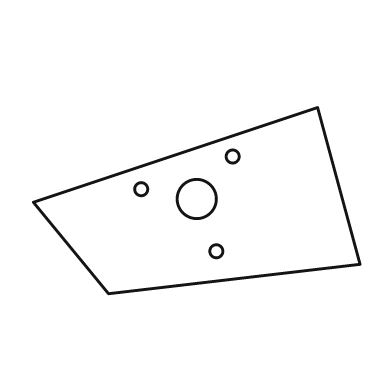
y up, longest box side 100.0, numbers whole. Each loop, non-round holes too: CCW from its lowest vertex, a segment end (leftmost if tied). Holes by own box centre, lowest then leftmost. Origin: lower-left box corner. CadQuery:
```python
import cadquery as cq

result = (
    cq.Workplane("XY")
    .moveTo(23.0, 0.0)
    .lineTo(100.0, 9.0)
    .lineTo(87.0, 57.0)
    .lineTo(0.0, 28.0)
    .close()
    .moveTo(56.0, 13.0)
    .circle(2.0)
    .moveTo(50.0, 29.0)
    .circle(6.0)
    .moveTo(33.0, 32.0)
    .circle(2.0)
    .moveTo(61.0, 42.0)
    .circle(2.0)
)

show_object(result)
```